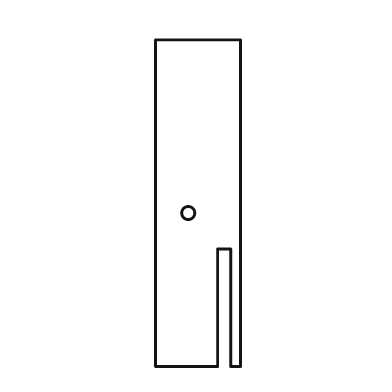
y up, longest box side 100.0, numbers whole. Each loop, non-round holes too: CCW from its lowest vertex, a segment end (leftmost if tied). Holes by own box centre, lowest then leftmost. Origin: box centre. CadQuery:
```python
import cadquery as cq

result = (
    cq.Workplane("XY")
    .moveTo(-13.0, -50.0)
    .lineTo(6.0, -50.0)
    .lineTo(6.0, -14.0)
    .lineTo(10.0, -14.0)
    .lineTo(10.0, -50.0)
    .lineTo(13.0, -50.0)
    .lineTo(13.0, 50.0)
    .lineTo(-13.0, 50.0)
    .close()
    .moveTo(-3.0, -3.0)
    .circle(2.0)
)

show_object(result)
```